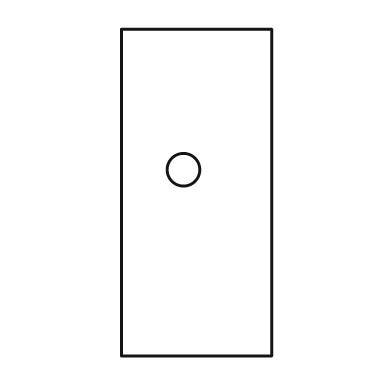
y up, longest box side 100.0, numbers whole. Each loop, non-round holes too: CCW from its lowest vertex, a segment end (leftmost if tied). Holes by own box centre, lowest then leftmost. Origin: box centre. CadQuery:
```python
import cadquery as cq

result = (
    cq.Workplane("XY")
    .moveTo(-23.0, -50.0)
    .lineTo(23.0, -50.0)
    .lineTo(23.0, 50.0)
    .lineTo(-23.0, 50.0)
    .close()
    .moveTo(-4.0, 7.0)
    .circle(5.0)
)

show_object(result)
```